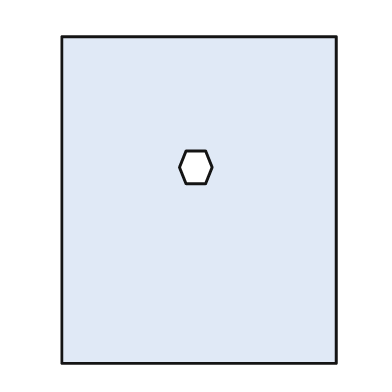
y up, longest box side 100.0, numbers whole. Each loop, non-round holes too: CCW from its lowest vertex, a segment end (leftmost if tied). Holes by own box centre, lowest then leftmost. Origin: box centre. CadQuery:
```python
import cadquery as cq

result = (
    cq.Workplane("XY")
    .moveTo(-42.0, -50.0)
    .lineTo(42.0, -50.0)
    .lineTo(42.0, 50.0)
    .lineTo(-42.0, 50.0)
    .close()
    .moveTo(-4.0, 5.0)
    .lineTo(2.0, 5.0)
    .lineTo(4.0, 10.0)
    .lineTo(2.0, 15.0)
    .lineTo(-4.0, 15.0)
    .lineTo(-6.0, 10.0)
    .close()
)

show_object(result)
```